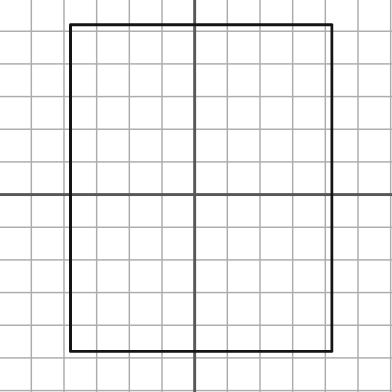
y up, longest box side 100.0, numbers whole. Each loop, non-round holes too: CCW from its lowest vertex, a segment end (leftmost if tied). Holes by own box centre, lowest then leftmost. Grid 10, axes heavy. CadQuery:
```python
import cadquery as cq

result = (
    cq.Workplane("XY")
    .moveTo(-38.0, -48.0)
    .lineTo(42.0, -48.0)
    .lineTo(42.0, 52.0)
    .lineTo(-38.0, 52.0)
    .close()
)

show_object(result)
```